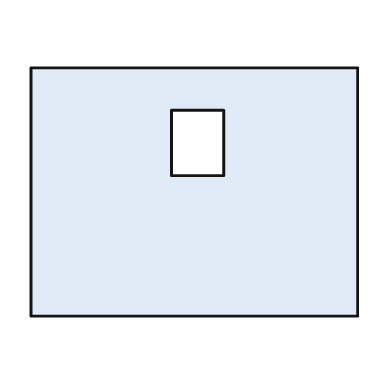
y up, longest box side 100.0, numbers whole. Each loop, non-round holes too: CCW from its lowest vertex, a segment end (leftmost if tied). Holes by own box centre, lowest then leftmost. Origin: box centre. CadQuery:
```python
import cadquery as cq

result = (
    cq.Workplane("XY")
    .moveTo(-50.0, -38.0)
    .lineTo(50.0, -38.0)
    .lineTo(50.0, 38.0)
    .lineTo(-50.0, 38.0)
    .close()
    .moveTo(-7.0, 5.0)
    .lineTo(9.0, 5.0)
    .lineTo(9.0, 25.0)
    .lineTo(-7.0, 25.0)
    .close()
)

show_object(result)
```